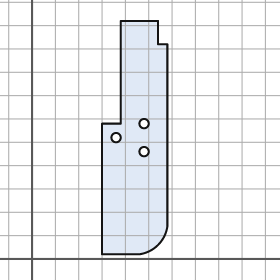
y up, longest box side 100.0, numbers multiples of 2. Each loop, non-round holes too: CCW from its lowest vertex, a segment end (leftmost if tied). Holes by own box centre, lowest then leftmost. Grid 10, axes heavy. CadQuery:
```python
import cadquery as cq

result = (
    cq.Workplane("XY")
    .moveTo(30.0, 2.0)
    .lineTo(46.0, 2.0)
    .threePointArc((54.0, 6.0), (58.0, 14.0))
    .lineTo(58.0, 92.0)
    .lineTo(54.0, 92.0)
    .lineTo(54.0, 102.0)
    .lineTo(38.0, 102.0)
    .lineTo(38.0, 58.0)
    .lineTo(30.0, 58.0)
    .close()
    .moveTo(48.0, 46.0)
    .circle(2.0)
    .moveTo(36.0, 52.0)
    .circle(2.0)
    .moveTo(48.0, 58.0)
    .circle(2.0)
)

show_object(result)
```